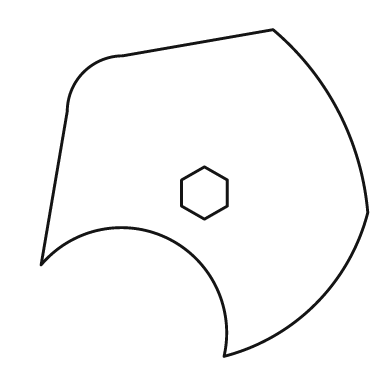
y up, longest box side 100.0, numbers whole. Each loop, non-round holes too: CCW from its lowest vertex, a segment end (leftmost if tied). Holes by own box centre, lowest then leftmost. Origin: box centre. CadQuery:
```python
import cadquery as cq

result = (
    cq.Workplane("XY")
    .moveTo(6.0, -50.0)
    .threePointArc((34.0, -34.0), (50.0, -6.0))
    .threePointArc((41.0, 25.0), (21.0, 50.0))
    .lineTo(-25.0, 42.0)
    .threePointArc((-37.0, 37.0), (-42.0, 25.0))
    .lineTo(-50.0, -22.0)
    .threePointArc((-11.0, -14.0), (6.0, -50.0))
    .close()
    .moveTo(0.0, -8.0)
    .lineTo(7.0, -4.0)
    .lineTo(7.0, 4.0)
    .lineTo(0.0, 8.0)
    .lineTo(-7.0, 4.0)
    .lineTo(-7.0, -4.0)
    .close()
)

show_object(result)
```